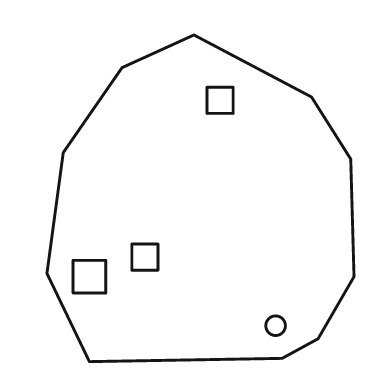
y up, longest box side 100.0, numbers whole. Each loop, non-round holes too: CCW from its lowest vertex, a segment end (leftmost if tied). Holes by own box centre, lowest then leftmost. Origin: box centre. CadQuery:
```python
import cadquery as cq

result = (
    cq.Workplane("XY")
    .moveTo(-34.0, -50.0)
    .lineTo(25.0, -49.0)
    .lineTo(36.0, -43.0)
    .lineTo(47.0, -24.0)
    .lineTo(46.0, 12.0)
    .lineTo(34.0, 31.0)
    .lineTo(-2.0, 50.0)
    .lineTo(-24.0, 40.0)
    .lineTo(-42.0, 14.0)
    .lineTo(-47.0, -23.0)
    .close()
    .moveTo(23.0, -39.0)
    .circle(3.0)
    .moveTo(-39.0, -29.0)
    .lineTo(-29.0, -29.0)
    .lineTo(-29.0, -19.0)
    .lineTo(-39.0, -19.0)
    .close()
    .moveTo(-21.0, -22.0)
    .lineTo(-13.0, -22.0)
    .lineTo(-13.0, -14.0)
    .lineTo(-21.0, -14.0)
    .close()
    .moveTo(2.0, 26.0)
    .lineTo(10.0, 26.0)
    .lineTo(10.0, 34.0)
    .lineTo(2.0, 34.0)
    .close()
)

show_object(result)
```